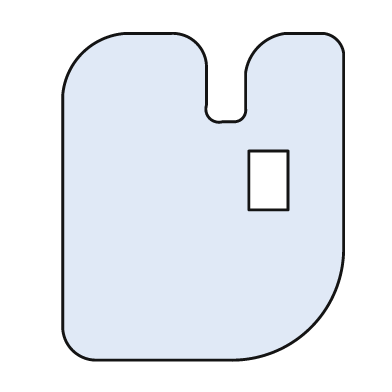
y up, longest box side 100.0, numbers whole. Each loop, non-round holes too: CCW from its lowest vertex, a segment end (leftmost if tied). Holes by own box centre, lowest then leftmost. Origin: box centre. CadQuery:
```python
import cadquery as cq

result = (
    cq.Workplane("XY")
    .moveTo(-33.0, -50.0)
    .lineTo(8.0, -50.0)
    .threePointArc((33.0, -40.0), (43.0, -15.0))
    .lineTo(43.0, 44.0)
    .threePointArc((41.0, 48.0), (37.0, 50.0))
    .lineTo(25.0, 50.0)
    .threePointArc((17.0, 46.0), (13.0, 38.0))
    .lineTo(13.0, 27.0)
    .threePointArc((12.0, 24.0), (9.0, 23.0))
    .lineTo(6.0, 23.0)
    .threePointArc((2.0, 24.0), (1.0, 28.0))
    .lineTo(1.0, 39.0)
    .threePointArc((-2.0, 47.0), (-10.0, 50.0))
    .lineTo(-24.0, 50.0)
    .threePointArc((-37.0, 44.0), (-43.0, 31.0))
    .lineTo(-43.0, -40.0)
    .threePointArc((-40.0, -47.0), (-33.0, -50.0))
    .close()
    .moveTo(14.0, -4.0)
    .lineTo(26.0, -4.0)
    .lineTo(26.0, 14.0)
    .lineTo(14.0, 14.0)
    .close()
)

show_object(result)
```